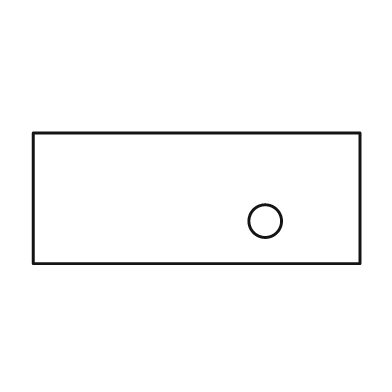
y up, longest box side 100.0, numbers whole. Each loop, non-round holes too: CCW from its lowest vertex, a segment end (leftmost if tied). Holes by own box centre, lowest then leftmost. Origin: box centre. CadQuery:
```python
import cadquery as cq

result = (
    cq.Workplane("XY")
    .moveTo(-50.0, -20.0)
    .lineTo(50.0, -20.0)
    .lineTo(50.0, 20.0)
    .lineTo(-50.0, 20.0)
    .close()
    .moveTo(21.0, -7.0)
    .circle(5.0)
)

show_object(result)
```